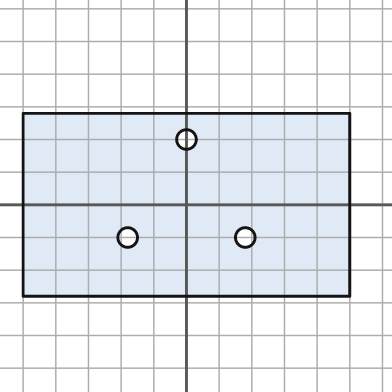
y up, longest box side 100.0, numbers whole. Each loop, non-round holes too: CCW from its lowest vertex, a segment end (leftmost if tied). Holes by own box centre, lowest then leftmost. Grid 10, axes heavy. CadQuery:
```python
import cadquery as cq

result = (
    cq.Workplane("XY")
    .moveTo(-50.0, -28.0)
    .lineTo(50.0, -28.0)
    .lineTo(50.0, 28.0)
    .lineTo(-50.0, 28.0)
    .close()
    .moveTo(-18.0, -10.0)
    .circle(3.0)
    .moveTo(18.0, -10.0)
    .circle(3.0)
    .moveTo(0.0, 20.0)
    .circle(3.0)
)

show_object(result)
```